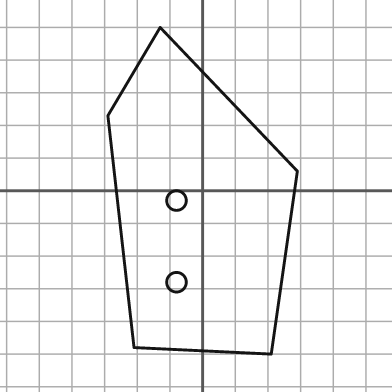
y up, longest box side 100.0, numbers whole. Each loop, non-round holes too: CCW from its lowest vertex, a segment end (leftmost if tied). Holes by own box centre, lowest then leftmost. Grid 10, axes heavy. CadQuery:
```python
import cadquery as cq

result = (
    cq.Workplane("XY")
    .moveTo(21.0, -50.0)
    .lineTo(29.0, 6.0)
    .lineTo(-13.0, 50.0)
    .lineTo(-29.0, 23.0)
    .lineTo(-21.0, -48.0)
    .close()
    .moveTo(-8.0, -28.0)
    .circle(3.0)
    .moveTo(-8.0, -3.0)
    .circle(3.0)
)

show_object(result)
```